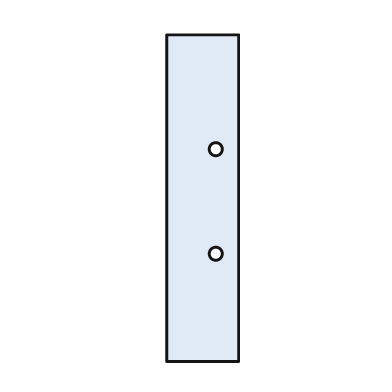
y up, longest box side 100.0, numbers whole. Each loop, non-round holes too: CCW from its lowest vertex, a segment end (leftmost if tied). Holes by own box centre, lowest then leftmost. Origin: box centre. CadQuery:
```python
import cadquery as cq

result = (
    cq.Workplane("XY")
    .moveTo(-11.0, -50.0)
    .lineTo(11.0, -50.0)
    .lineTo(11.0, 50.0)
    .lineTo(-11.0, 50.0)
    .close()
    .moveTo(4.0, -17.0)
    .circle(2.0)
    .moveTo(4.0, 15.0)
    .circle(2.0)
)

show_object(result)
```